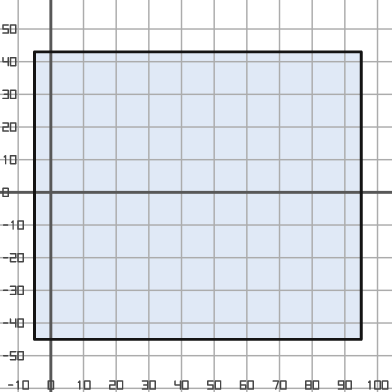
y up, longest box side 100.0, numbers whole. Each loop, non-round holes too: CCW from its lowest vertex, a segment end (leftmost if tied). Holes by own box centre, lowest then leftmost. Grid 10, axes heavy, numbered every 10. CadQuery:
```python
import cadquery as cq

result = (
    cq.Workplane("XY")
    .moveTo(-5.0, -45.0)
    .lineTo(95.0, -45.0)
    .lineTo(95.0, 43.0)
    .lineTo(-5.0, 43.0)
    .close()
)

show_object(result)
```